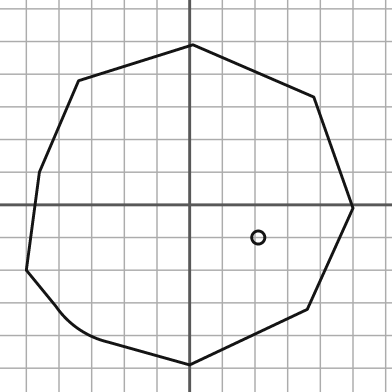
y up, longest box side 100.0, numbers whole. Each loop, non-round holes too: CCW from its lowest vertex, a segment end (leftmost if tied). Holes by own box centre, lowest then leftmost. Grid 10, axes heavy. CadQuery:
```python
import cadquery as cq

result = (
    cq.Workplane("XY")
    .moveTo(0.0, -49.0)
    .lineTo(36.0, -32.0)
    .lineTo(50.0, -1.0)
    .lineTo(38.0, 33.0)
    .lineTo(1.0, 49.0)
    .lineTo(-34.0, 38.0)
    .lineTo(-46.0, 10.0)
    .lineTo(-50.0, -20.0)
    .lineTo(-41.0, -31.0)
    .threePointArc((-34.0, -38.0), (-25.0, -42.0))
    .close()
    .moveTo(21.0, -10.0)
    .circle(2.0)
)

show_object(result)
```